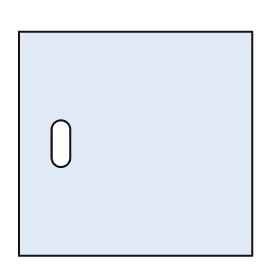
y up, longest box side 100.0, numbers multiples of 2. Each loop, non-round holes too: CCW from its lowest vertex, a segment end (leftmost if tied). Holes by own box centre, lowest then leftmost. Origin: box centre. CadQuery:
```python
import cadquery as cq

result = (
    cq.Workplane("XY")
    .moveTo(-50.0, -48.0)
    .lineTo(50.0, -48.0)
    .lineTo(50.0, 48.0)
    .lineTo(-50.0, 48.0)
    .close()
    .moveTo(-36.0, -6.0)
    .threePointArc((-32.0, -10.0), (-28.0, -6.0))
    .lineTo(-28.0, 6.0)
    .threePointArc((-32.0, 10.0), (-36.0, 6.0))
    .close()
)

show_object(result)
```